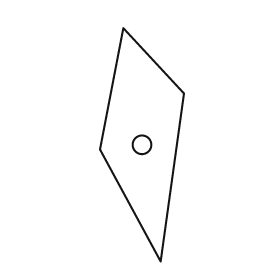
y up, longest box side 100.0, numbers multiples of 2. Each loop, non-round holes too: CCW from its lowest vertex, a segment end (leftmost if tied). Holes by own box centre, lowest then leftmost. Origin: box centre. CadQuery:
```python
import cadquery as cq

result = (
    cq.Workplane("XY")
    .moveTo(8.0, -50.0)
    .lineTo(18.0, 22.0)
    .lineTo(-8.0, 50.0)
    .lineTo(-18.0, -2.0)
    .close()
    .moveTo(0.0, 0.0)
    .circle(4.0)
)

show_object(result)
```